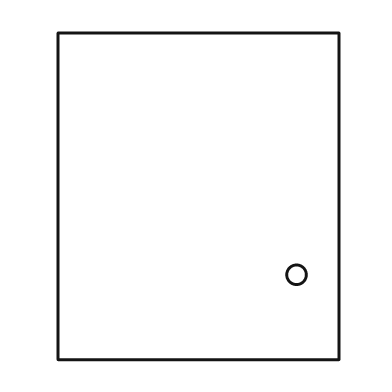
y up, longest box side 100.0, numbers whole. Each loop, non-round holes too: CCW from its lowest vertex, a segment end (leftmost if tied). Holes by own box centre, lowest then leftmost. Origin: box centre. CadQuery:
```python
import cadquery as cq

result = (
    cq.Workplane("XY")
    .moveTo(-43.0, -50.0)
    .lineTo(43.0, -50.0)
    .lineTo(43.0, 50.0)
    .lineTo(-43.0, 50.0)
    .close()
    .moveTo(30.0, -24.0)
    .circle(3.0)
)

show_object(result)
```